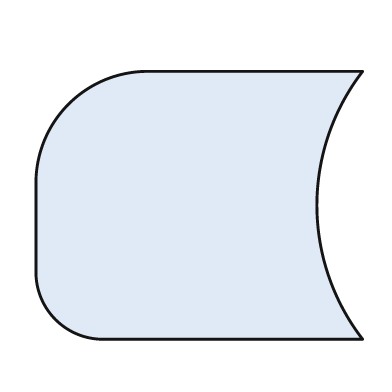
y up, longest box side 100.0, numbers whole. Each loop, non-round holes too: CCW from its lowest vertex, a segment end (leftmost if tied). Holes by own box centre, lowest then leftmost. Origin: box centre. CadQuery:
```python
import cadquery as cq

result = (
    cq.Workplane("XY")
    .moveTo(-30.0, -41.0)
    .lineTo(50.0, -41.0)
    .threePointArc((36.0, 0.0), (50.0, 41.0))
    .lineTo(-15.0, 41.0)
    .threePointArc((-40.0, 31.0), (-50.0, 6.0))
    .lineTo(-50.0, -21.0)
    .threePointArc((-44.0, -35.0), (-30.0, -41.0))
    .close()
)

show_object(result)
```